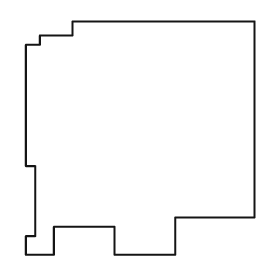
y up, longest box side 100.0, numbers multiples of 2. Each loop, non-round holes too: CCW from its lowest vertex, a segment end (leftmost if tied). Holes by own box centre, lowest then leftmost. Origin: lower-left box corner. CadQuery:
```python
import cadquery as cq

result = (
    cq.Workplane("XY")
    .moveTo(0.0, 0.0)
    .lineTo(12.0, 0.0)
    .lineTo(12.0, 12.0)
    .lineTo(38.0, 12.0)
    .lineTo(38.0, 0.0)
    .lineTo(64.0, 0.0)
    .lineTo(64.0, 16.0)
    .lineTo(98.0, 16.0)
    .lineTo(98.0, 100.0)
    .lineTo(20.0, 100.0)
    .lineTo(20.0, 94.0)
    .lineTo(6.0, 94.0)
    .lineTo(6.0, 90.0)
    .lineTo(0.0, 90.0)
    .lineTo(0.0, 38.0)
    .lineTo(4.0, 38.0)
    .lineTo(4.0, 8.0)
    .lineTo(0.0, 8.0)
    .close()
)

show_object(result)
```